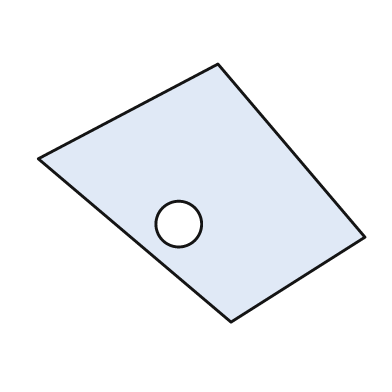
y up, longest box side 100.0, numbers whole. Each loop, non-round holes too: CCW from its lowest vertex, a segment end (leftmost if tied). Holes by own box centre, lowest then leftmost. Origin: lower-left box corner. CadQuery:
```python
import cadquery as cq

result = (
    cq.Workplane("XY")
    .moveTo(59.0, 0.0)
    .lineTo(100.0, 26.0)
    .lineTo(55.0, 79.0)
    .lineTo(0.0, 50.0)
    .close()
    .moveTo(43.0, 30.0)
    .circle(7.0)
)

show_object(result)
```